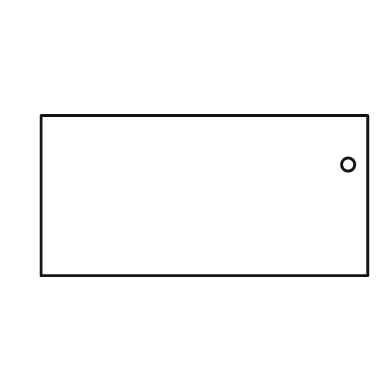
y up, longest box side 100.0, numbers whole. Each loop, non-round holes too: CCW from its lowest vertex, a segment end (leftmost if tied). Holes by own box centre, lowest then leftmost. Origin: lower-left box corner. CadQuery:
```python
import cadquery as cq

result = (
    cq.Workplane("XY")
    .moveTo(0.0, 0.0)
    .lineTo(100.0, 0.0)
    .lineTo(100.0, 49.0)
    .lineTo(0.0, 49.0)
    .close()
    .moveTo(94.0, 34.0)
    .circle(2.0)
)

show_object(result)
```